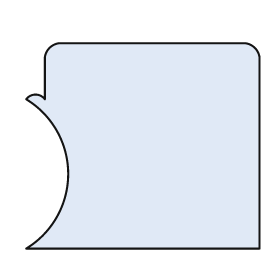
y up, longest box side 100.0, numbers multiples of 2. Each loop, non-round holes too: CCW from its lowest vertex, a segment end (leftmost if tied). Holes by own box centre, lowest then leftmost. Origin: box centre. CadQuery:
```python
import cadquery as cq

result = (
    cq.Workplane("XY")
    .moveTo(-50.0, -44.0)
    .lineTo(50.0, -44.0)
    .lineTo(50.0, 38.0)
    .threePointArc((48.0, 42.0), (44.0, 44.0))
    .lineTo(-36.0, 44.0)
    .threePointArc((-40.0, 42.0), (-42.0, 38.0))
    .lineTo(-42.0, 20.0)
    .threePointArc((-46.0, 22.0), (-50.0, 20.0))
    .threePointArc((-32.0, -12.0), (-50.0, -44.0))
    .close()
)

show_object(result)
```